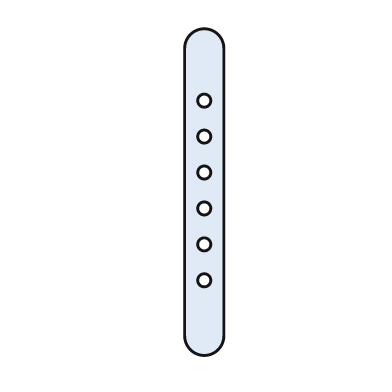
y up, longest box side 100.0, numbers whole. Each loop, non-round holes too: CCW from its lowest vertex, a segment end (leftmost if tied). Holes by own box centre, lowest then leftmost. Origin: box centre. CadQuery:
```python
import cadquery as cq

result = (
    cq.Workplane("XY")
    .moveTo(-6.0, -44.0)
    .threePointArc((0.0, -50.0), (6.0, -44.0))
    .lineTo(6.0, 44.0)
    .threePointArc((0.0, 50.0), (-6.0, 44.0))
    .close()
    .moveTo(0.0, -27.0)
    .circle(2.0)
    .moveTo(0.0, -16.0)
    .circle(2.0)
    .moveTo(0.0, -5.0)
    .circle(2.0)
    .moveTo(0.0, 6.0)
    .circle(2.0)
    .moveTo(0.0, 17.0)
    .circle(2.0)
    .moveTo(0.0, 28.0)
    .circle(2.0)
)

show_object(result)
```